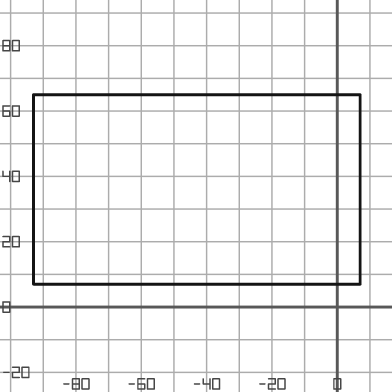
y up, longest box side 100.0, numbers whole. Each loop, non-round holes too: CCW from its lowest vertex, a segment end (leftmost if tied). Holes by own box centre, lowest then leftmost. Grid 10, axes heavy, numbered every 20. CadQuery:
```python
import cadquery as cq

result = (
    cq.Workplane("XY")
    .moveTo(-93.0, 7.0)
    .lineTo(7.0, 7.0)
    .lineTo(7.0, 65.0)
    .lineTo(-93.0, 65.0)
    .close()
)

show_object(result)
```